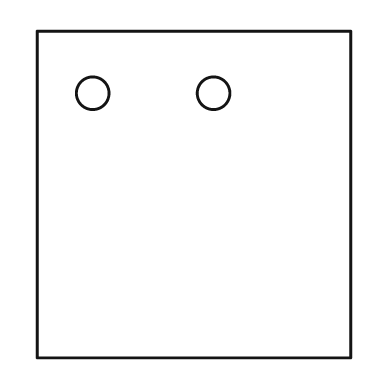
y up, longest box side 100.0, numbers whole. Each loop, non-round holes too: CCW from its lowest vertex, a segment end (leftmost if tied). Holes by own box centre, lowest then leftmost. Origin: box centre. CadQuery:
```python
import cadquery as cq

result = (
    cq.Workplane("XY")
    .moveTo(-48.0, -50.0)
    .lineTo(48.0, -50.0)
    .lineTo(48.0, 50.0)
    .lineTo(-48.0, 50.0)
    .close()
    .moveTo(-31.0, 31.0)
    .circle(5.0)
    .moveTo(6.0, 31.0)
    .circle(5.0)
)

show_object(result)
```